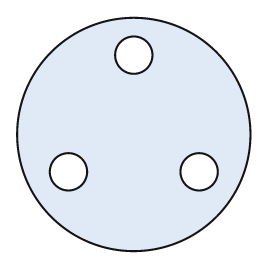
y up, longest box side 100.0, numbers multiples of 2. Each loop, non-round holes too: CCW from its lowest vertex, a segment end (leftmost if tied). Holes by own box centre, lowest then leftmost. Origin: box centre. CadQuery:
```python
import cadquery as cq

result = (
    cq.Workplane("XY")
    .moveTo(0.0, 0.0)
    .circle(50.0)
    .moveTo(-28.0, -16.0)
    .circle(8.0)
    .moveTo(28.0, -16.0)
    .circle(8.0)
    .moveTo(0.0, 34.0)
    .circle(8.0)
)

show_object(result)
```